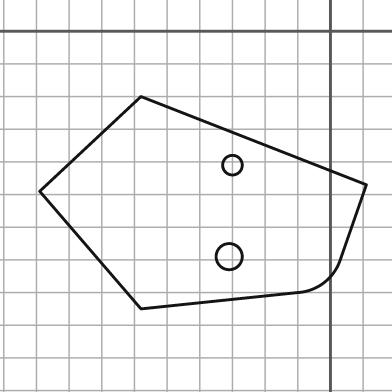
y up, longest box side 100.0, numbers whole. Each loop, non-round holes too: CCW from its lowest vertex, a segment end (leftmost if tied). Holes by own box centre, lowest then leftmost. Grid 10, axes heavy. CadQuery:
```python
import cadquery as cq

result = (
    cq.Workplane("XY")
    .moveTo(-58.0, -85.0)
    .lineTo(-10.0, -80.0)
    .threePointArc((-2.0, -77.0), (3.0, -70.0))
    .lineTo(11.0, -47.0)
    .lineTo(-58.0, -20.0)
    .lineTo(-89.0, -49.0)
    .close()
    .moveTo(-31.0, -69.0)
    .circle(4.0)
    .moveTo(-30.0, -41.0)
    .circle(3.0)
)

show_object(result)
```